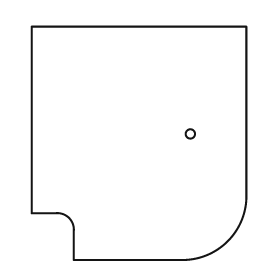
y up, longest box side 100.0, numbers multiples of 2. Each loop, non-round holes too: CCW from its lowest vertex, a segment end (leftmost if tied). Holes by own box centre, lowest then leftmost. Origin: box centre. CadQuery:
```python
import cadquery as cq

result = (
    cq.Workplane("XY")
    .moveTo(-28.0, -50.0)
    .lineTo(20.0, -50.0)
    .threePointArc((38.0, -42.0), (46.0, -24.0))
    .lineTo(46.0, 50.0)
    .lineTo(-46.0, 50.0)
    .lineTo(-46.0, -30.0)
    .lineTo(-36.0, -30.0)
    .threePointArc((-30.0, -32.0), (-28.0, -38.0))
    .close()
    .moveTo(22.0, 4.0)
    .circle(2.0)
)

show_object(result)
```